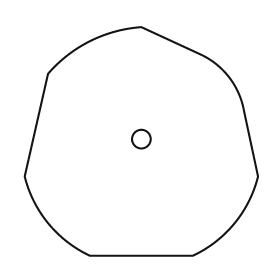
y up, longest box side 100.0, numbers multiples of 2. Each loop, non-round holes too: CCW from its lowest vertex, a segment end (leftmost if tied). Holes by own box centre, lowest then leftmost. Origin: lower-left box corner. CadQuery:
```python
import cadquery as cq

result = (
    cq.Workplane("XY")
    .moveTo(28.0, 0.0)
    .lineTo(72.0, 0.0)
    .threePointArc((90.0, 14.0), (100.0, 34.0))
    .lineTo(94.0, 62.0)
    .threePointArc((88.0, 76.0), (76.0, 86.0))
    .lineTo(50.0, 98.0)
    .threePointArc((28.0, 92.0), (10.0, 78.0))
    .lineTo(0.0, 34.0)
    .threePointArc((10.0, 14.0), (28.0, 0.0))
    .close()
    .moveTo(50.0, 50.0)
    .circle(4.0)
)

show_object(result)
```